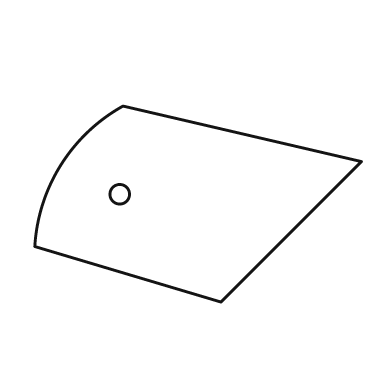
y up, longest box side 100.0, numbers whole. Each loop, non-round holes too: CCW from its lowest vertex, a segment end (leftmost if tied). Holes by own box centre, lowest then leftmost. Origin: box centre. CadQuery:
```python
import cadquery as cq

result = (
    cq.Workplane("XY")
    .moveTo(7.0, -30.0)
    .lineTo(50.0, 13.0)
    .lineTo(-23.0, 30.0)
    .threePointArc((-42.0, 12.0), (-50.0, -13.0))
    .close()
    .moveTo(-24.0, 3.0)
    .circle(3.0)
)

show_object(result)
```